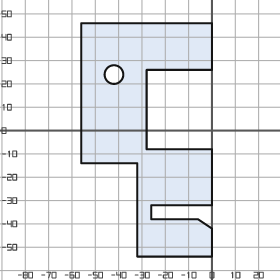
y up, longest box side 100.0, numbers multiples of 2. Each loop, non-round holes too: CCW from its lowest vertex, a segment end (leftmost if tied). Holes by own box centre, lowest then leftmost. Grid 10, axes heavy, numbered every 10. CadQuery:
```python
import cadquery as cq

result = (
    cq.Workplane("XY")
    .moveTo(-32.0, -54.0)
    .lineTo(0.0, -54.0)
    .lineTo(0.0, -42.0)
    .lineTo(-6.0, -38.0)
    .lineTo(-26.0, -38.0)
    .lineTo(-26.0, -32.0)
    .lineTo(0.0, -32.0)
    .lineTo(0.0, -8.0)
    .lineTo(-28.0, -8.0)
    .lineTo(-28.0, 26.0)
    .lineTo(0.0, 26.0)
    .lineTo(0.0, 46.0)
    .lineTo(-56.0, 46.0)
    .lineTo(-56.0, -14.0)
    .lineTo(-32.0, -14.0)
    .close()
    .moveTo(-42.0, 24.0)
    .circle(4.0)
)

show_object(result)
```